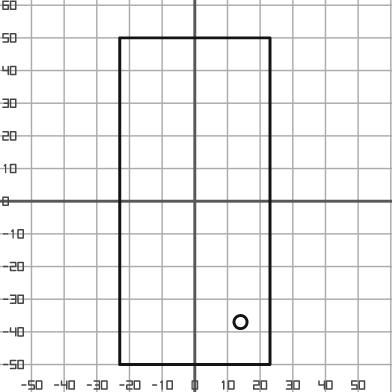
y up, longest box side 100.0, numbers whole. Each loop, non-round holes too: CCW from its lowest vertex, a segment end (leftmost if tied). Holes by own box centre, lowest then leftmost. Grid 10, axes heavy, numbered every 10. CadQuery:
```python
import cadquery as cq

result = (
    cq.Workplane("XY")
    .moveTo(-23.0, -50.0)
    .lineTo(23.0, -50.0)
    .lineTo(23.0, 50.0)
    .lineTo(-23.0, 50.0)
    .close()
    .moveTo(14.0, -37.0)
    .circle(2.0)
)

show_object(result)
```